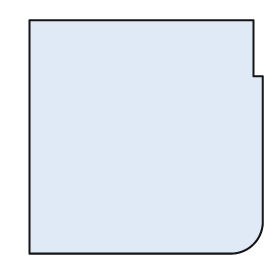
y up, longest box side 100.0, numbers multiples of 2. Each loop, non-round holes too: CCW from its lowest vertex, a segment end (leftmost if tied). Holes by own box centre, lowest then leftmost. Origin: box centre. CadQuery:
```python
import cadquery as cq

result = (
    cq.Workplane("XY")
    .moveTo(-50.0, -50.0)
    .lineTo(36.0, -50.0)
    .threePointArc((46.0, -46.0), (50.0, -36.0))
    .lineTo(50.0, 26.0)
    .lineTo(46.0, 26.0)
    .lineTo(46.0, 50.0)
    .lineTo(-50.0, 50.0)
    .close()
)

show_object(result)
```